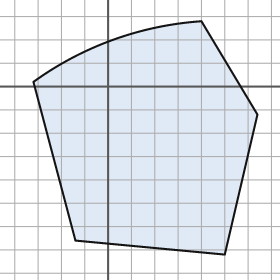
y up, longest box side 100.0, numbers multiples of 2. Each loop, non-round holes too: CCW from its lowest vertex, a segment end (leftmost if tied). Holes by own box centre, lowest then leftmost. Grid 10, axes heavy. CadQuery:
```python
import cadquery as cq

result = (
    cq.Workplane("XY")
    .moveTo(50.0, -72.0)
    .lineTo(64.0, -12.0)
    .lineTo(40.0, 28.0)
    .threePointArc((2.0, 20.0), (-32.0, 2.0))
    .lineTo(-14.0, -66.0)
    .close()
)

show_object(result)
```